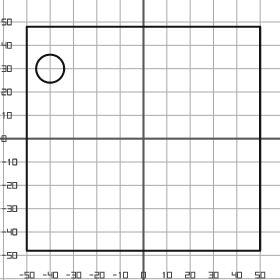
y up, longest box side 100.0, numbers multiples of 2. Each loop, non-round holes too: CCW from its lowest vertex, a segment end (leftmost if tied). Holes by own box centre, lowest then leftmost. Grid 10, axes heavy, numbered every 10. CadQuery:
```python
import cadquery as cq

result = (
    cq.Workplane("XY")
    .moveTo(-50.0, -48.0)
    .lineTo(50.0, -48.0)
    .lineTo(50.0, 48.0)
    .lineTo(-50.0, 48.0)
    .close()
    .moveTo(-40.0, 30.0)
    .circle(6.0)
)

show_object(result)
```